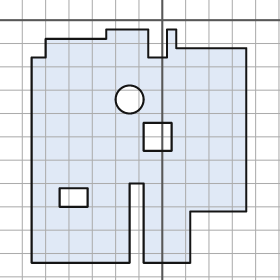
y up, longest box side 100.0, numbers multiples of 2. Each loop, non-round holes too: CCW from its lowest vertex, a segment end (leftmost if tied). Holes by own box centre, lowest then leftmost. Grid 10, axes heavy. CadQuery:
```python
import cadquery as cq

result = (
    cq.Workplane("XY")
    .moveTo(-56.0, -104.0)
    .lineTo(-14.0, -104.0)
    .lineTo(-14.0, -70.0)
    .lineTo(-8.0, -70.0)
    .lineTo(-8.0, -104.0)
    .lineTo(12.0, -104.0)
    .lineTo(12.0, -82.0)
    .lineTo(36.0, -82.0)
    .lineTo(36.0, -12.0)
    .lineTo(6.0, -12.0)
    .lineTo(6.0, -4.0)
    .lineTo(2.0, -4.0)
    .lineTo(2.0, -16.0)
    .lineTo(-6.0, -16.0)
    .lineTo(-6.0, -4.0)
    .lineTo(-24.0, -4.0)
    .lineTo(-24.0, -8.0)
    .lineTo(-50.0, -8.0)
    .lineTo(-50.0, -16.0)
    .lineTo(-56.0, -16.0)
    .close()
    .moveTo(-44.0, -80.0)
    .lineTo(-32.0, -80.0)
    .lineTo(-32.0, -72.0)
    .lineTo(-44.0, -72.0)
    .close()
    .moveTo(-8.0, -56.0)
    .lineTo(4.0, -56.0)
    .lineTo(4.0, -44.0)
    .lineTo(-8.0, -44.0)
    .close()
    .moveTo(-14.0, -34.0)
    .circle(6.0)
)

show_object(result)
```